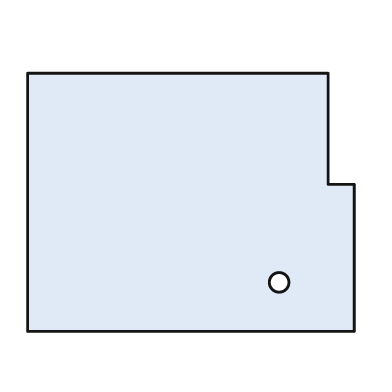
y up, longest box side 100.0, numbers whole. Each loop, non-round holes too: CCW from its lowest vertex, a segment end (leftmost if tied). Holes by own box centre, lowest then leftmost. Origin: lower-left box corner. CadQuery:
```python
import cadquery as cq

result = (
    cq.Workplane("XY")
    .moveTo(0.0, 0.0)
    .lineTo(100.0, 0.0)
    .lineTo(100.0, 45.0)
    .lineTo(92.0, 45.0)
    .lineTo(92.0, 79.0)
    .lineTo(0.0, 79.0)
    .close()
    .moveTo(77.0, 15.0)
    .circle(3.0)
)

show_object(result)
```